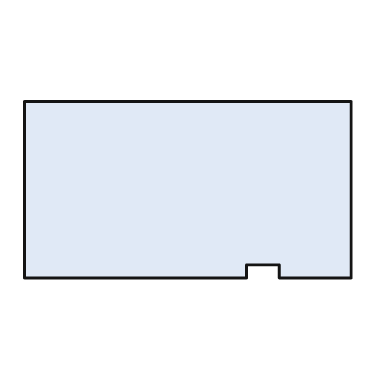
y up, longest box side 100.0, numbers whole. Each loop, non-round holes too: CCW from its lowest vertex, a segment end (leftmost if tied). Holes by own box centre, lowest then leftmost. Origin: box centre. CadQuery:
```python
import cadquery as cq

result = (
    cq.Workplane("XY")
    .moveTo(-50.0, -27.0)
    .lineTo(18.0, -27.0)
    .lineTo(18.0, -23.0)
    .lineTo(28.0, -23.0)
    .lineTo(28.0, -27.0)
    .lineTo(50.0, -27.0)
    .lineTo(50.0, 27.0)
    .lineTo(-50.0, 27.0)
    .close()
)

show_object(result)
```